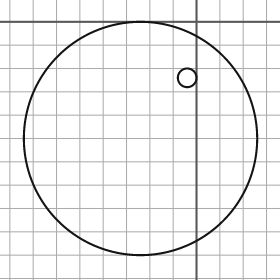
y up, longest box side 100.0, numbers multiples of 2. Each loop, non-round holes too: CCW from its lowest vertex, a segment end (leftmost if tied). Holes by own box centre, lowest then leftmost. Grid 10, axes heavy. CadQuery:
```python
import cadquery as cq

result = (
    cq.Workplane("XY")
    .moveTo(-24.0, -50.0)
    .circle(50.0)
    .moveTo(-4.0, -24.0)
    .circle(4.0)
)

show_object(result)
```